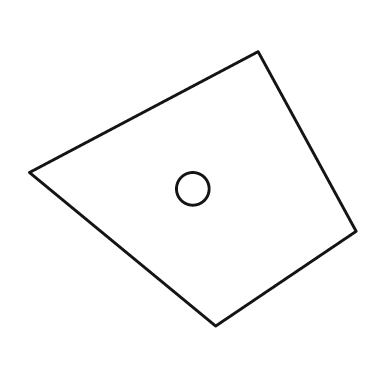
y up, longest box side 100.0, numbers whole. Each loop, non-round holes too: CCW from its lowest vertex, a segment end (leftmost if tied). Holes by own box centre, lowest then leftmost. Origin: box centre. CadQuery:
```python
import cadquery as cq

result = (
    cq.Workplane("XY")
    .moveTo(7.0, -42.0)
    .lineTo(50.0, -13.0)
    .lineTo(20.0, 42.0)
    .lineTo(-50.0, 5.0)
    .close()
    .moveTo(0.0, 0.0)
    .circle(5.0)
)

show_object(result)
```